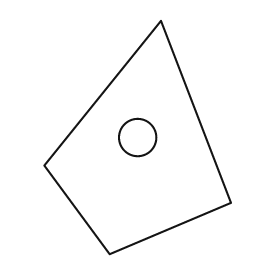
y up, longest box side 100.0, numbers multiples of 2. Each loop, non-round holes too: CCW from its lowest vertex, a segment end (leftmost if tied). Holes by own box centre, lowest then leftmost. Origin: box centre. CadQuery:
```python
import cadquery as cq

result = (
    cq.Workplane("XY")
    .moveTo(-12.0, -50.0)
    .lineTo(40.0, -28.0)
    .lineTo(10.0, 50.0)
    .lineTo(-40.0, -12.0)
    .close()
    .moveTo(0.0, 0.0)
    .circle(8.0)
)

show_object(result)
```